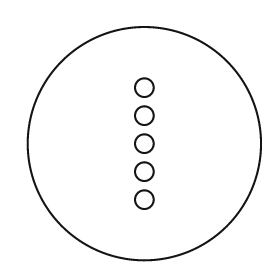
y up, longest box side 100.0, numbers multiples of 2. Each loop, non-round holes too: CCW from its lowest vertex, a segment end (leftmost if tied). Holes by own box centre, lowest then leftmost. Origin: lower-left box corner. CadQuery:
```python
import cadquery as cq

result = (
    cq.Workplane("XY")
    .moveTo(50.0, 50.0)
    .circle(50.0)
    .moveTo(50.0, 26.0)
    .circle(4.0)
    .moveTo(50.0, 38.0)
    .circle(4.0)
    .moveTo(50.0, 50.0)
    .circle(4.0)
    .moveTo(50.0, 62.0)
    .circle(4.0)
    .moveTo(50.0, 74.0)
    .circle(4.0)
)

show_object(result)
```